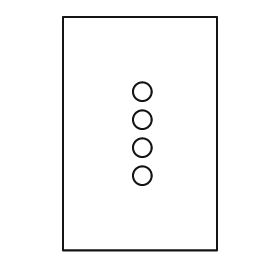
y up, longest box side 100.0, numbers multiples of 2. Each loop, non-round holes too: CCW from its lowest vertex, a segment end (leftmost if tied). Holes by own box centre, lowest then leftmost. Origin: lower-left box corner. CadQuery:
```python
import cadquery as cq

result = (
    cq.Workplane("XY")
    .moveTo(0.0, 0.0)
    .lineTo(66.0, 0.0)
    .lineTo(66.0, 100.0)
    .lineTo(0.0, 100.0)
    .close()
    .moveTo(34.0, 32.0)
    .circle(4.0)
    .moveTo(34.0, 44.0)
    .circle(4.0)
    .moveTo(34.0, 56.0)
    .circle(4.0)
    .moveTo(34.0, 68.0)
    .circle(4.0)
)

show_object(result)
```